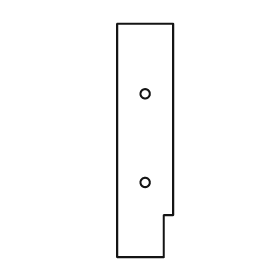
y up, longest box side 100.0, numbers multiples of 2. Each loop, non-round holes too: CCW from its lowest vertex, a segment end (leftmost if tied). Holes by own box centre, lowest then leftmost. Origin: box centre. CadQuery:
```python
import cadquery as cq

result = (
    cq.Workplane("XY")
    .moveTo(-12.0, -50.0)
    .lineTo(8.0, -50.0)
    .lineTo(8.0, -32.0)
    .lineTo(12.0, -32.0)
    .lineTo(12.0, 50.0)
    .lineTo(-12.0, 50.0)
    .close()
    .moveTo(0.0, -18.0)
    .circle(2.0)
    .moveTo(0.0, 20.0)
    .circle(2.0)
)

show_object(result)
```